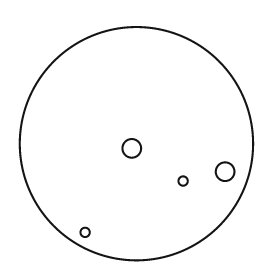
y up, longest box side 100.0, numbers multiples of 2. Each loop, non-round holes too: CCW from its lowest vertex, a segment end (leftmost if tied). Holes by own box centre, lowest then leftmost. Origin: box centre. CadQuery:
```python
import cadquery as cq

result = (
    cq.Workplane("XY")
    .moveTo(0.0, 0.0)
    .circle(50.0)
    .moveTo(-22.0, -38.0)
    .circle(2.0)
    .moveTo(20.0, -16.0)
    .circle(2.0)
    .moveTo(38.0, -12.0)
    .circle(4.0)
    .moveTo(-2.0, -2.0)
    .circle(4.0)
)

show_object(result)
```